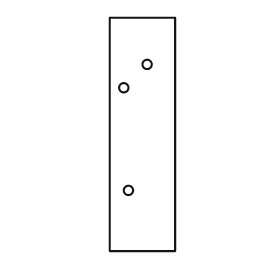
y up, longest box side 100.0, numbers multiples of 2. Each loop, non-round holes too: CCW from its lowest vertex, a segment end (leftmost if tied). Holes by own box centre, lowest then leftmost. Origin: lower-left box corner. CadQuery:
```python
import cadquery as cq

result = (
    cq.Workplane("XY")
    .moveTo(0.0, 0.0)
    .lineTo(28.0, 0.0)
    .lineTo(28.0, 100.0)
    .lineTo(0.0, 100.0)
    .close()
    .moveTo(8.0, 26.0)
    .circle(2.0)
    .moveTo(6.0, 70.0)
    .circle(2.0)
    .moveTo(16.0, 80.0)
    .circle(2.0)
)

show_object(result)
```